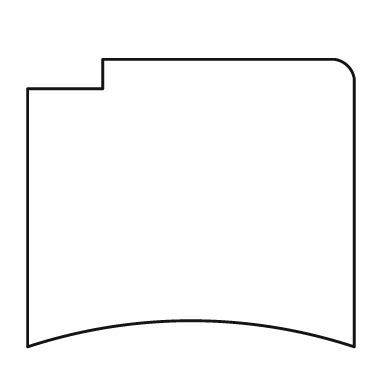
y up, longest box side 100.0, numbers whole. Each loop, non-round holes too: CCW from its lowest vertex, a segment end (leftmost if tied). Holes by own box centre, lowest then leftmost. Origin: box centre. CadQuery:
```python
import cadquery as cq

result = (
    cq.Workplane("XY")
    .moveTo(-50.0, -44.0)
    .threePointArc((0.0, -36.0), (50.0, -44.0))
    .lineTo(50.0, 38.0)
    .threePointArc((48.0, 42.0), (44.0, 44.0))
    .lineTo(-27.0, 44.0)
    .lineTo(-27.0, 35.0)
    .lineTo(-50.0, 35.0)
    .close()
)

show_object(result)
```